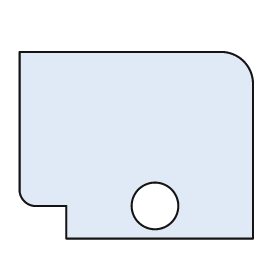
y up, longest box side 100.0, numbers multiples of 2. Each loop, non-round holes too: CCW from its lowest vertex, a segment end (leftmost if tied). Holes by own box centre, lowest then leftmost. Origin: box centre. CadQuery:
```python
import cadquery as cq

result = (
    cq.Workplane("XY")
    .moveTo(-30.0, -40.0)
    .lineTo(50.0, -40.0)
    .lineTo(50.0, 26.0)
    .threePointArc((46.0, 36.0), (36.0, 40.0))
    .lineTo(-50.0, 40.0)
    .lineTo(-50.0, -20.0)
    .threePointArc((-48.0, -24.0), (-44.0, -26.0))
    .lineTo(-30.0, -26.0)
    .close()
    .moveTo(8.0, -26.0)
    .circle(10.0)
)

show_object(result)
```